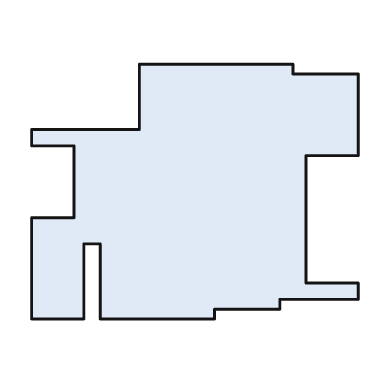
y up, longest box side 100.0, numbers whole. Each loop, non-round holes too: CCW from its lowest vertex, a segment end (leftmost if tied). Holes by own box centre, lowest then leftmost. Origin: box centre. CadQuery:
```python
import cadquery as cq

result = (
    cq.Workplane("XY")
    .moveTo(-50.0, -39.0)
    .lineTo(-34.0, -39.0)
    .lineTo(-34.0, -16.0)
    .lineTo(-29.0, -16.0)
    .lineTo(-29.0, -39.0)
    .lineTo(6.0, -39.0)
    .lineTo(6.0, -36.0)
    .lineTo(26.0, -36.0)
    .lineTo(26.0, -33.0)
    .lineTo(50.0, -33.0)
    .lineTo(50.0, -28.0)
    .lineTo(34.0, -28.0)
    .lineTo(34.0, 11.0)
    .lineTo(50.0, 11.0)
    .lineTo(50.0, 36.0)
    .lineTo(30.0, 36.0)
    .lineTo(30.0, 39.0)
    .lineTo(-17.0, 39.0)
    .lineTo(-17.0, 19.0)
    .lineTo(-50.0, 19.0)
    .lineTo(-50.0, 14.0)
    .lineTo(-37.0, 14.0)
    .lineTo(-37.0, -8.0)
    .lineTo(-50.0, -8.0)
    .close()
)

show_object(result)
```